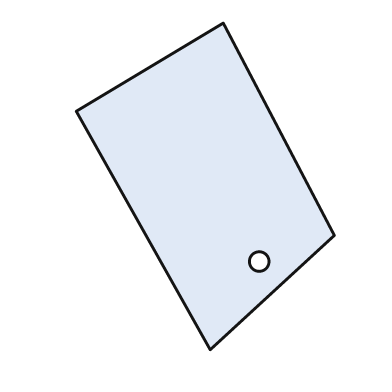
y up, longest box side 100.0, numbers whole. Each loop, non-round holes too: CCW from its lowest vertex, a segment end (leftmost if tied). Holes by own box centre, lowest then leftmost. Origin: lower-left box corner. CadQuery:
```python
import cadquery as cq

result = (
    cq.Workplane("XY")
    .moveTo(41.0, 0.0)
    .lineTo(79.0, 35.0)
    .lineTo(45.0, 100.0)
    .lineTo(0.0, 73.0)
    .close()
    .moveTo(56.0, 27.0)
    .circle(3.0)
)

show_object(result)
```